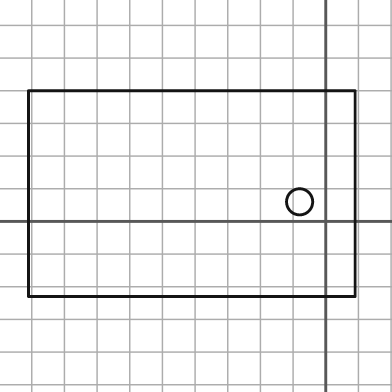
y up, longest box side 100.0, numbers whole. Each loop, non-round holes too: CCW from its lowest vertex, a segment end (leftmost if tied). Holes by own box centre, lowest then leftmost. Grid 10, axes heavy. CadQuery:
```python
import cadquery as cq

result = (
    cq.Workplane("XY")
    .moveTo(-91.0, -23.0)
    .lineTo(9.0, -23.0)
    .lineTo(9.0, 40.0)
    .lineTo(-91.0, 40.0)
    .close()
    .moveTo(-8.0, 6.0)
    .circle(4.0)
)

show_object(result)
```